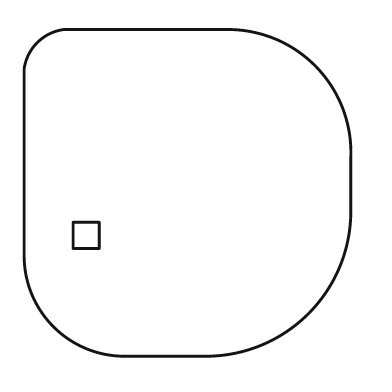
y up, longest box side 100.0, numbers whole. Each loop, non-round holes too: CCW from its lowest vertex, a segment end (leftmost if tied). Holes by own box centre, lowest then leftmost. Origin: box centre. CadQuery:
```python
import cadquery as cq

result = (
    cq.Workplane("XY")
    .moveTo(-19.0, -50.0)
    .lineTo(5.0, -50.0)
    .threePointArc((37.0, -37.0), (50.0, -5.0))
    .lineTo(50.0, 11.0)
    .threePointArc((39.0, 39.0), (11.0, 50.0))
    .lineTo(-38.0, 50.0)
    .threePointArc((-46.0, 46.0), (-50.0, 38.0))
    .lineTo(-50.0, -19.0)
    .threePointArc((-41.0, -41.0), (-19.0, -50.0))
    .close()
    .moveTo(-35.0, -17.0)
    .lineTo(-27.0, -17.0)
    .lineTo(-27.0, -9.0)
    .lineTo(-35.0, -9.0)
    .close()
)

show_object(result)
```